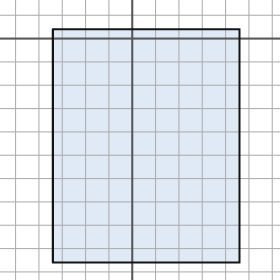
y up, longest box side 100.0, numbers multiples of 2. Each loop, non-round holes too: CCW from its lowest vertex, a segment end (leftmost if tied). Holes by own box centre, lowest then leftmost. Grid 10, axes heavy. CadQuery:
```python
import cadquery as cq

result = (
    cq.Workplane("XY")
    .moveTo(-34.0, -96.0)
    .lineTo(46.0, -96.0)
    .lineTo(46.0, 4.0)
    .lineTo(-34.0, 4.0)
    .close()
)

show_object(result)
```